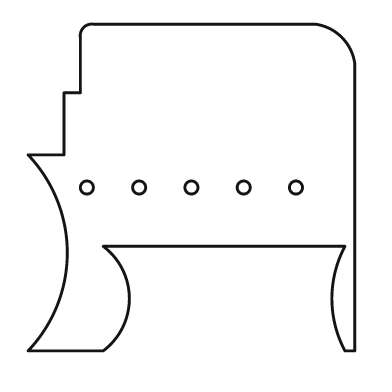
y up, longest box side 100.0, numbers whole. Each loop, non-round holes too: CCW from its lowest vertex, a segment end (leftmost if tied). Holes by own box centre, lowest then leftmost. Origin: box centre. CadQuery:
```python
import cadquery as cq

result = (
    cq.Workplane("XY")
    .moveTo(-50.0, -50.0)
    .lineTo(-27.0, -50.0)
    .threePointArc((-19.0, -34.0), (-27.0, -18.0))
    .lineTo(47.0, -18.0)
    .threePointArc((43.0, -34.0), (47.0, -50.0))
    .lineTo(50.0, -50.0)
    .lineTo(50.0, 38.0)
    .threePointArc((46.0, 46.0), (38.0, 50.0))
    .lineTo(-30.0, 50.0)
    .threePointArc((-33.0, 49.0), (-34.0, 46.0))
    .lineTo(-34.0, 29.0)
    .lineTo(-39.0, 29.0)
    .lineTo(-39.0, 10.0)
    .lineTo(-50.0, 10.0)
    .threePointArc((-38.0, -20.0), (-50.0, -50.0))
    .close()
    .moveTo(-32.0, 0.0)
    .circle(2.0)
    .moveTo(-16.0, 0.0)
    .circle(2.0)
    .moveTo(0.0, 0.0)
    .circle(2.0)
    .moveTo(16.0, 0.0)
    .circle(2.0)
    .moveTo(32.0, 0.0)
    .circle(2.0)
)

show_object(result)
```